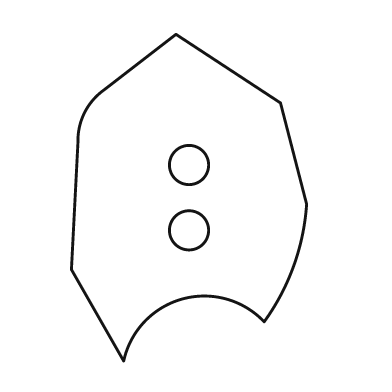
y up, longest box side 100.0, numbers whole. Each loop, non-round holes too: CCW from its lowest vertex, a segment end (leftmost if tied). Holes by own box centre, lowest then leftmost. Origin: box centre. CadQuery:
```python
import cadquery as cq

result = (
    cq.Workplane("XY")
    .moveTo(-20.0, -50.0)
    .threePointArc((-2.0, -31.0), (23.0, -38.0))
    .threePointArc((32.0, -21.0), (36.0, -2.0))
    .lineTo(28.0, 29.0)
    .lineTo(-4.0, 50.0)
    .lineTo(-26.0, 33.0)
    .threePointArc((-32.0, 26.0), (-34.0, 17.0))
    .lineTo(-36.0, -22.0)
    .close()
    .moveTo(0.0, -10.0)
    .circle(6.0)
    .moveTo(0.0, 10.0)
    .circle(6.0)
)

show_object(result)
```